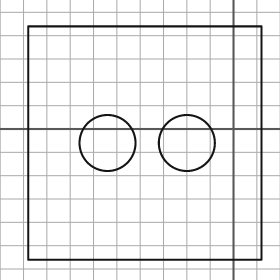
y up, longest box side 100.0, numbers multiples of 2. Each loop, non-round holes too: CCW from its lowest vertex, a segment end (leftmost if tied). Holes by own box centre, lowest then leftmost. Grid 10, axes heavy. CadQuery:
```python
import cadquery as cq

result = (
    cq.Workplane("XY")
    .moveTo(-88.0, -56.0)
    .lineTo(12.0, -56.0)
    .lineTo(12.0, 44.0)
    .lineTo(-88.0, 44.0)
    .close()
    .moveTo(-54.0, -6.0)
    .circle(12.0)
    .moveTo(-20.0, -6.0)
    .circle(12.0)
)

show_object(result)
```